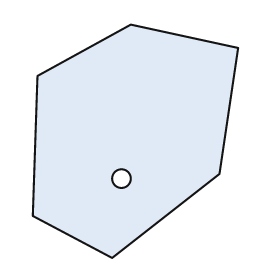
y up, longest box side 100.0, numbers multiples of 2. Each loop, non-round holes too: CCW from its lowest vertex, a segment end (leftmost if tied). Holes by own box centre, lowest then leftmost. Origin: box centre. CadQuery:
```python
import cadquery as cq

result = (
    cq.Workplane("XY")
    .moveTo(-10.0, -50.0)
    .lineTo(36.0, -14.0)
    .lineTo(44.0, 40.0)
    .lineTo(-2.0, 50.0)
    .lineTo(-42.0, 28.0)
    .lineTo(-44.0, -32.0)
    .close()
    .moveTo(-6.0, -16.0)
    .circle(4.0)
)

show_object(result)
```